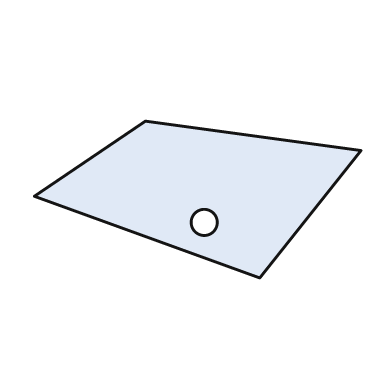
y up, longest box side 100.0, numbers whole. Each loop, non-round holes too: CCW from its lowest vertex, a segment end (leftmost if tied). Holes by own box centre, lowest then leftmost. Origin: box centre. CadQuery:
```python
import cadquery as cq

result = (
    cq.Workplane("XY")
    .moveTo(19.0, -24.0)
    .lineTo(50.0, 15.0)
    .lineTo(-16.0, 24.0)
    .lineTo(-50.0, 1.0)
    .close()
    .moveTo(2.0, -7.0)
    .circle(4.0)
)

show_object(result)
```